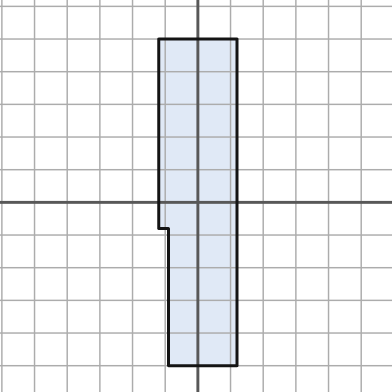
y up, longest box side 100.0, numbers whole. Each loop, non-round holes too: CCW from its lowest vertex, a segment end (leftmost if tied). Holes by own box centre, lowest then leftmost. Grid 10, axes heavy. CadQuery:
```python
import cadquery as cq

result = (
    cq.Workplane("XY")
    .moveTo(-9.0, -50.0)
    .lineTo(12.0, -50.0)
    .lineTo(12.0, 50.0)
    .lineTo(-12.0, 50.0)
    .lineTo(-12.0, -8.0)
    .lineTo(-9.0, -8.0)
    .close()
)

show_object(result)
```